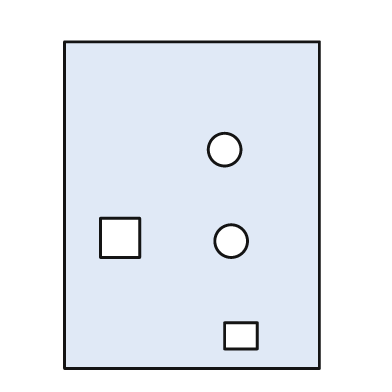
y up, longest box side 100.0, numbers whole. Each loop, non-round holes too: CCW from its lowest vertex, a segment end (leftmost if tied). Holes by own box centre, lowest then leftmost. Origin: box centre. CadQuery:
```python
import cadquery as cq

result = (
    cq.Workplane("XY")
    .moveTo(-39.0, -50.0)
    .lineTo(39.0, -50.0)
    .lineTo(39.0, 50.0)
    .lineTo(-39.0, 50.0)
    .close()
    .moveTo(10.0, -44.0)
    .lineTo(20.0, -44.0)
    .lineTo(20.0, -36.0)
    .lineTo(10.0, -36.0)
    .close()
    .moveTo(12.0, -11.0)
    .circle(5.0)
    .moveTo(-28.0, -16.0)
    .lineTo(-16.0, -16.0)
    .lineTo(-16.0, -4.0)
    .lineTo(-28.0, -4.0)
    .close()
    .moveTo(10.0, 17.0)
    .circle(5.0)
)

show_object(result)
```